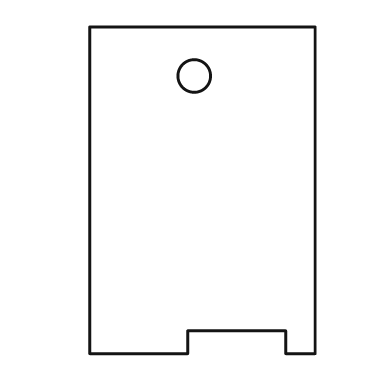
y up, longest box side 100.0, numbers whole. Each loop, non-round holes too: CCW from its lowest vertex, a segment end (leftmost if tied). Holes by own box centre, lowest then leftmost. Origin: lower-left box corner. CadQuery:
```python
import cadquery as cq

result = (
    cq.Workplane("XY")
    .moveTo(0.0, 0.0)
    .lineTo(30.0, 0.0)
    .lineTo(30.0, 7.0)
    .lineTo(60.0, 7.0)
    .lineTo(60.0, 0.0)
    .lineTo(69.0, 0.0)
    .lineTo(69.0, 100.0)
    .lineTo(0.0, 100.0)
    .close()
    .moveTo(32.0, 85.0)
    .circle(5.0)
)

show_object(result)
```